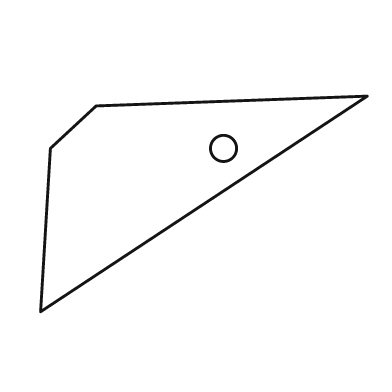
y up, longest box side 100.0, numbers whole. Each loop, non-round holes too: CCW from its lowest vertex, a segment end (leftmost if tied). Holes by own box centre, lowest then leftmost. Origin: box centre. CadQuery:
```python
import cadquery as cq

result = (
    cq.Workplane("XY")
    .moveTo(-50.0, -33.0)
    .lineTo(50.0, 33.0)
    .lineTo(-33.0, 30.0)
    .lineTo(-47.0, 17.0)
    .close()
    .moveTo(6.0, 17.0)
    .circle(4.0)
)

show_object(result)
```